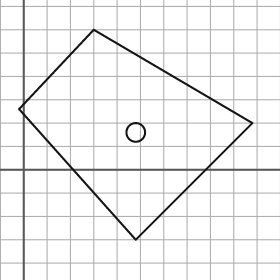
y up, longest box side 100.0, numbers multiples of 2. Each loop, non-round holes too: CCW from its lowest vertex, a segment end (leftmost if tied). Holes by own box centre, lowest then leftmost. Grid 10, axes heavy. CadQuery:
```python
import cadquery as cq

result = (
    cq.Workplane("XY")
    .moveTo(48.0, -30.0)
    .lineTo(98.0, 20.0)
    .lineTo(30.0, 60.0)
    .lineTo(-2.0, 26.0)
    .close()
    .moveTo(48.0, 16.0)
    .circle(4.0)
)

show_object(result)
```